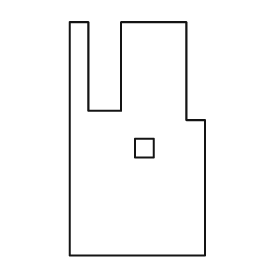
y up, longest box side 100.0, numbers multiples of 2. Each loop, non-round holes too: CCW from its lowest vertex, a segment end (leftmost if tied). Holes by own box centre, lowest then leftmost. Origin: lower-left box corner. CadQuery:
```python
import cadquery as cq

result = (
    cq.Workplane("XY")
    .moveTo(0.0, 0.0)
    .lineTo(58.0, 0.0)
    .lineTo(58.0, 58.0)
    .lineTo(50.0, 58.0)
    .lineTo(50.0, 100.0)
    .lineTo(22.0, 100.0)
    .lineTo(22.0, 62.0)
    .lineTo(8.0, 62.0)
    .lineTo(8.0, 100.0)
    .lineTo(0.0, 100.0)
    .close()
    .moveTo(28.0, 42.0)
    .lineTo(36.0, 42.0)
    .lineTo(36.0, 50.0)
    .lineTo(28.0, 50.0)
    .close()
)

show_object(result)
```